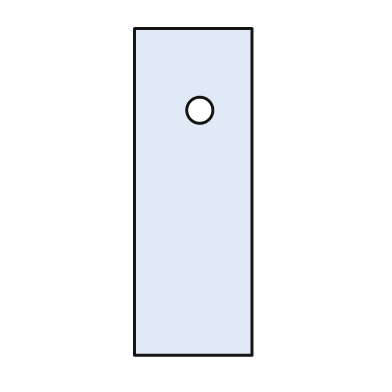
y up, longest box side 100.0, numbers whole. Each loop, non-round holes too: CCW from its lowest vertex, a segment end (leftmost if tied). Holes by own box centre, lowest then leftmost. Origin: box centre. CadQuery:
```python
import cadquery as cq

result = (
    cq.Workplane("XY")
    .moveTo(-18.0, -50.0)
    .lineTo(18.0, -50.0)
    .lineTo(18.0, 50.0)
    .lineTo(-18.0, 50.0)
    .close()
    .moveTo(2.0, 25.0)
    .circle(4.0)
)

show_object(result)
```